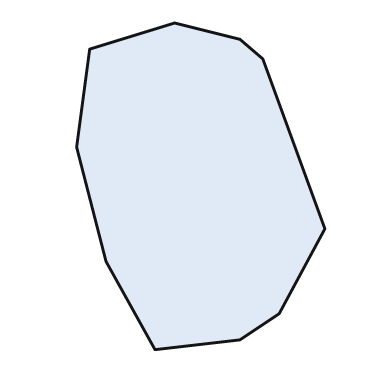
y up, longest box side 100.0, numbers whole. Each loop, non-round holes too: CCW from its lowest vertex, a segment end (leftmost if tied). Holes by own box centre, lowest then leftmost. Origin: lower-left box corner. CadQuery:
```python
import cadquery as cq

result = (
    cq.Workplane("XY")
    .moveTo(24.0, 0.0)
    .lineTo(50.0, 3.0)
    .lineTo(62.0, 11.0)
    .lineTo(76.0, 37.0)
    .lineTo(57.0, 89.0)
    .lineTo(50.0, 95.0)
    .lineTo(30.0, 100.0)
    .lineTo(4.0, 92.0)
    .lineTo(0.0, 62.0)
    .lineTo(9.0, 27.0)
    .close()
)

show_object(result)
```